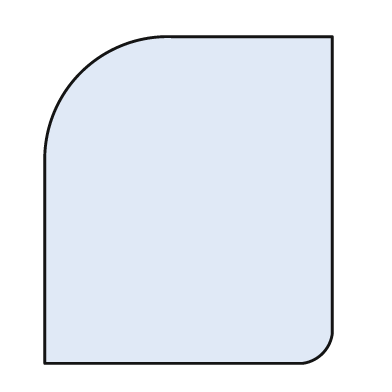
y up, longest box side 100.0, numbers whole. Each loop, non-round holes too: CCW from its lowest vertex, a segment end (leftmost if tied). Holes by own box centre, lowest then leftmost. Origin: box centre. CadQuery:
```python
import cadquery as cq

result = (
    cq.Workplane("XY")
    .moveTo(-44.0, -50.0)
    .lineTo(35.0, -50.0)
    .threePointArc((41.0, -47.0), (44.0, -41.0))
    .lineTo(44.0, 50.0)
    .lineTo(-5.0, 50.0)
    .threePointArc((-33.0, 39.0), (-44.0, 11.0))
    .close()
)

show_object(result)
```